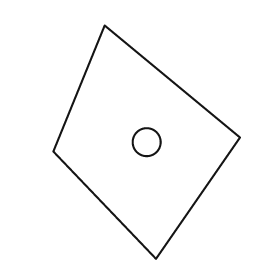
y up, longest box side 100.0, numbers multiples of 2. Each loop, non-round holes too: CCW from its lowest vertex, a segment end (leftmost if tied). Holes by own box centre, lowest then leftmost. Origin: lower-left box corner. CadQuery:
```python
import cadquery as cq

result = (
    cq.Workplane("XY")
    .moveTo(44.0, 0.0)
    .lineTo(80.0, 52.0)
    .lineTo(22.0, 100.0)
    .lineTo(0.0, 46.0)
    .close()
    .moveTo(40.0, 50.0)
    .circle(6.0)
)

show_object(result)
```